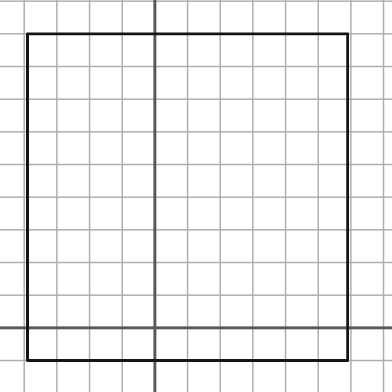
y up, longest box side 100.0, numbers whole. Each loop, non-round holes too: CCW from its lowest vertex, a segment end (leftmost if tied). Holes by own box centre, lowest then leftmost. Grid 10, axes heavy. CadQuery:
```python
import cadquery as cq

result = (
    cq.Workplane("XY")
    .moveTo(-39.0, -10.0)
    .lineTo(59.0, -10.0)
    .lineTo(59.0, 90.0)
    .lineTo(-39.0, 90.0)
    .close()
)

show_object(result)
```